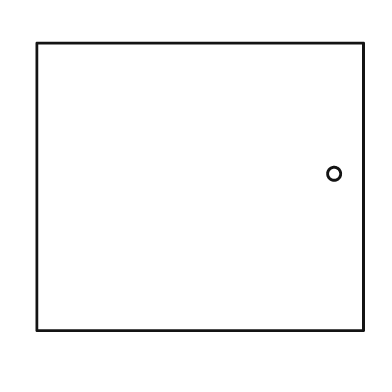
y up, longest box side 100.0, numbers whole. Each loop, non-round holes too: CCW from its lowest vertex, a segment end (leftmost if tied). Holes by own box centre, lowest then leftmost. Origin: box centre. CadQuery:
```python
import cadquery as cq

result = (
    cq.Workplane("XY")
    .moveTo(-50.0, -44.0)
    .lineTo(50.0, -44.0)
    .lineTo(50.0, 44.0)
    .lineTo(-50.0, 44.0)
    .close()
    .moveTo(41.0, 4.0)
    .circle(2.0)
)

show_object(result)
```